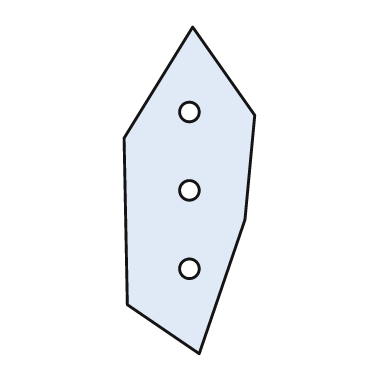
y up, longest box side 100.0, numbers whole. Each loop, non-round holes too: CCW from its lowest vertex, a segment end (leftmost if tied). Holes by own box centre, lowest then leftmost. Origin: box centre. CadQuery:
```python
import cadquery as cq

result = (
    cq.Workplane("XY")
    .moveTo(3.0, -50.0)
    .lineTo(17.0, -9.0)
    .lineTo(20.0, 23.0)
    .lineTo(1.0, 50.0)
    .lineTo(-20.0, 16.0)
    .lineTo(-19.0, -35.0)
    .close()
    .moveTo(0.0, -24.0)
    .circle(3.0)
    .moveTo(0.0, 0.0)
    .circle(3.0)
    .moveTo(0.0, 24.0)
    .circle(3.0)
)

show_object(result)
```